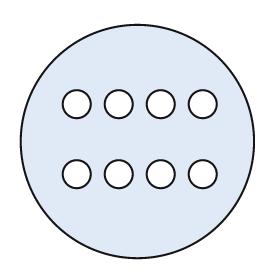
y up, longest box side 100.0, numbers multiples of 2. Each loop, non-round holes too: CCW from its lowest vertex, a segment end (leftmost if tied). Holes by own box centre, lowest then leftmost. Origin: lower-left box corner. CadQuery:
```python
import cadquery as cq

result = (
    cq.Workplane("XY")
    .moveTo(50.0, 50.0)
    .circle(50.0)
    .moveTo(24.0, 36.0)
    .circle(6.0)
    .moveTo(42.0, 36.0)
    .circle(6.0)
    .moveTo(60.0, 36.0)
    .circle(6.0)
    .moveTo(78.0, 36.0)
    .circle(6.0)
    .moveTo(24.0, 66.0)
    .circle(6.0)
    .moveTo(42.0, 66.0)
    .circle(6.0)
    .moveTo(60.0, 66.0)
    .circle(6.0)
    .moveTo(78.0, 66.0)
    .circle(6.0)
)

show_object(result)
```